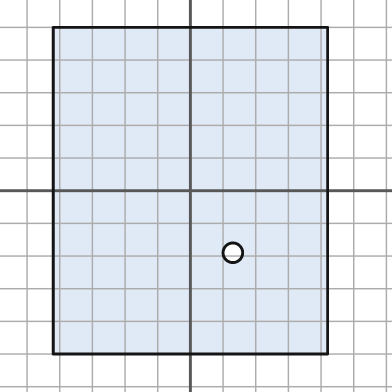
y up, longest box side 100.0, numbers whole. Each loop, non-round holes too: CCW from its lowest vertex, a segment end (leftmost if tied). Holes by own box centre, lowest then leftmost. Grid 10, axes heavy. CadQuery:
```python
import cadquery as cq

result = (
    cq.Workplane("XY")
    .moveTo(-42.0, -50.0)
    .lineTo(42.0, -50.0)
    .lineTo(42.0, 50.0)
    .lineTo(-42.0, 50.0)
    .close()
    .moveTo(13.0, -19.0)
    .circle(3.0)
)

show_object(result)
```